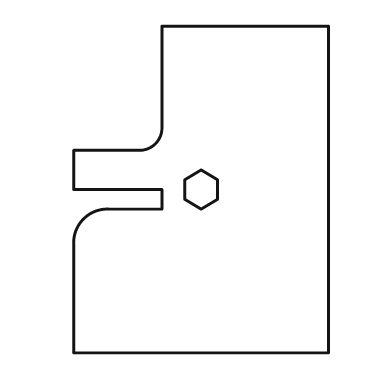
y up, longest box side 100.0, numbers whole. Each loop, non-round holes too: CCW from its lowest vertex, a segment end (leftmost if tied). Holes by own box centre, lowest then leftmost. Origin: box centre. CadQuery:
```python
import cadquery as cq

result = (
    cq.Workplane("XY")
    .moveTo(-39.0, -50.0)
    .lineTo(39.0, -50.0)
    .lineTo(39.0, 50.0)
    .lineTo(-12.0, 50.0)
    .lineTo(-12.0, 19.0)
    .threePointArc((-14.0, 14.0), (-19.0, 12.0))
    .lineTo(-39.0, 12.0)
    .lineTo(-39.0, 0.0)
    .lineTo(-12.0, 0.0)
    .lineTo(-12.0, -6.0)
    .lineTo(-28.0, -6.0)
    .threePointArc((-36.0, -9.0), (-39.0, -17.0))
    .close()
    .moveTo(0.0, -6.0)
    .lineTo(5.0, -3.0)
    .lineTo(5.0, 3.0)
    .lineTo(0.0, 6.0)
    .lineTo(-5.0, 3.0)
    .lineTo(-5.0, -3.0)
    .close()
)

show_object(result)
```